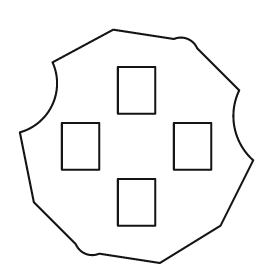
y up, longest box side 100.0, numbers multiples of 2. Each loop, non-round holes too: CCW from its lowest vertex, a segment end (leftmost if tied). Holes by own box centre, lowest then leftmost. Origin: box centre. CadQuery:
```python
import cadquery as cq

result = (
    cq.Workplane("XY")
    .moveTo(10.0, -50.0)
    .lineTo(36.0, -34.0)
    .lineTo(50.0, -6.0)
    .threePointArc((42.0, 8.0), (44.0, 24.0))
    .lineTo(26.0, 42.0)
    .threePointArc((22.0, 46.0), (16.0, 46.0))
    .lineTo(-10.0, 50.0)
    .lineTo(-36.0, 36.0)
    .threePointArc((-36.0, 18.0), (-50.0, 6.0))
    .lineTo(-44.0, -24.0)
    .lineTo(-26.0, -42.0)
    .threePointArc((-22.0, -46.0), (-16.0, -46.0))
    .close()
    .moveTo(-8.0, -34.0)
    .lineTo(8.0, -34.0)
    .lineTo(8.0, -14.0)
    .lineTo(-8.0, -14.0)
    .close()
    .moveTo(-32.0, -10.0)
    .lineTo(-16.0, -10.0)
    .lineTo(-16.0, 10.0)
    .lineTo(-32.0, 10.0)
    .close()
    .moveTo(16.0, -10.0)
    .lineTo(32.0, -10.0)
    .lineTo(32.0, 10.0)
    .lineTo(16.0, 10.0)
    .close()
    .moveTo(-8.0, 14.0)
    .lineTo(8.0, 14.0)
    .lineTo(8.0, 34.0)
    .lineTo(-8.0, 34.0)
    .close()
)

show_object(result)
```